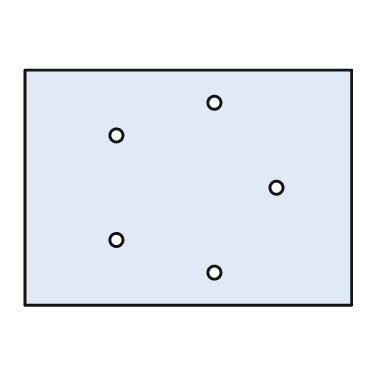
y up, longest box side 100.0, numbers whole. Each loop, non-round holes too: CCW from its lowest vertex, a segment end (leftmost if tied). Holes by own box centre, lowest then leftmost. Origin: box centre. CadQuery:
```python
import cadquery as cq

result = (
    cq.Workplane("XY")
    .moveTo(-50.0, -36.0)
    .lineTo(50.0, -36.0)
    .lineTo(50.0, 36.0)
    .lineTo(-50.0, 36.0)
    .close()
    .moveTo(8.0, -26.0)
    .circle(2.0)
    .moveTo(-22.0, -16.0)
    .circle(2.0)
    .moveTo(27.0, 0.0)
    .circle(2.0)
    .moveTo(-22.0, 16.0)
    .circle(2.0)
    .moveTo(8.0, 26.0)
    .circle(2.0)
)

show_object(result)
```